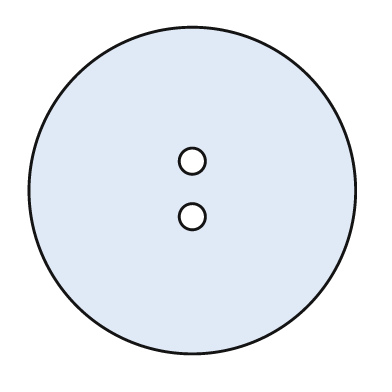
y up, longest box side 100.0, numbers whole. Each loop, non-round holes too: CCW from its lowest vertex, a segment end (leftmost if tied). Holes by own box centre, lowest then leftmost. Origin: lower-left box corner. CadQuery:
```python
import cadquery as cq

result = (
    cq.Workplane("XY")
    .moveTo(50.0, 50.0)
    .circle(50.0)
    .moveTo(50.0, 42.0)
    .circle(4.0)
    .moveTo(50.0, 59.0)
    .circle(4.0)
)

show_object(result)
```